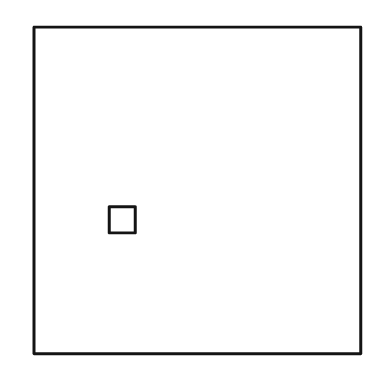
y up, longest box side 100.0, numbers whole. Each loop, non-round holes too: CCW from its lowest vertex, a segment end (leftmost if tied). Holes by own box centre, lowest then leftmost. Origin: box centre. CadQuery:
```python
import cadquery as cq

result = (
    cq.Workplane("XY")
    .moveTo(-50.0, -50.0)
    .lineTo(50.0, -50.0)
    .lineTo(50.0, 50.0)
    .lineTo(-50.0, 50.0)
    .close()
    .moveTo(-27.0, -13.0)
    .lineTo(-19.0, -13.0)
    .lineTo(-19.0, -5.0)
    .lineTo(-27.0, -5.0)
    .close()
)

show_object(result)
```